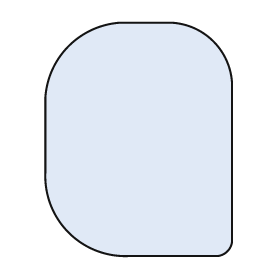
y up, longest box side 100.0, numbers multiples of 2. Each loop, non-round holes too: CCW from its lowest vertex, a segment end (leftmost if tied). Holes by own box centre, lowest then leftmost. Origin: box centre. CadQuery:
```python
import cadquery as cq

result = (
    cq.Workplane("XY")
    .moveTo(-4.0, -50.0)
    .lineTo(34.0, -50.0)
    .threePointArc((38.0, -48.0), (40.0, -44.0))
    .lineTo(40.0, 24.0)
    .threePointArc((32.0, 42.0), (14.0, 50.0))
    .lineTo(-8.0, 50.0)
    .threePointArc((-30.0, 40.0), (-40.0, 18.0))
    .lineTo(-40.0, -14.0)
    .threePointArc((-30.0, -40.0), (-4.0, -50.0))
    .close()
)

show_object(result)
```